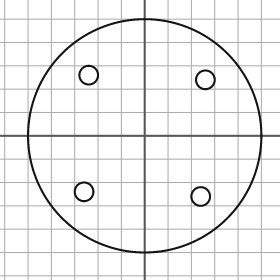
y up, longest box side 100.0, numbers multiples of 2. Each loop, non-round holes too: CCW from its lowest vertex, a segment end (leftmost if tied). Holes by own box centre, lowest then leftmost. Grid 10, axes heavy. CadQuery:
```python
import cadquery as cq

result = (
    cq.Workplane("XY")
    .moveTo(0.0, 0.0)
    .circle(50.0)
    .moveTo(24.0, -26.0)
    .circle(4.0)
    .moveTo(-26.0, -24.0)
    .circle(4.0)
    .moveTo(26.0, 24.0)
    .circle(4.0)
    .moveTo(-24.0, 26.0)
    .circle(4.0)
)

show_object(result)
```